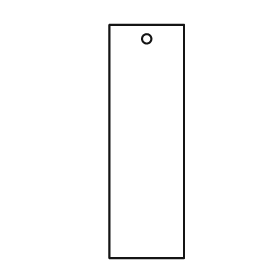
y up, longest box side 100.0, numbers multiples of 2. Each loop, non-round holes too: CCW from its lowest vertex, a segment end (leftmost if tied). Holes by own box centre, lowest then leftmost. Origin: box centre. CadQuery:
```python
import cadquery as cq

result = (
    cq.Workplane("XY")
    .moveTo(-16.0, -50.0)
    .lineTo(16.0, -50.0)
    .lineTo(16.0, 50.0)
    .lineTo(-16.0, 50.0)
    .close()
    .moveTo(0.0, 44.0)
    .circle(2.0)
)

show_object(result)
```